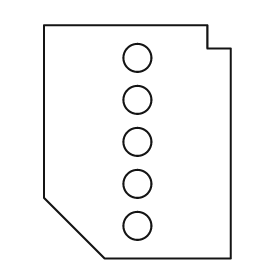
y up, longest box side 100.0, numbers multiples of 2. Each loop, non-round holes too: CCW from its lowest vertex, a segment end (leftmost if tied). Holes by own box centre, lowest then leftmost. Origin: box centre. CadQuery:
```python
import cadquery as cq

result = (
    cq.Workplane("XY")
    .moveTo(-14.0, -50.0)
    .lineTo(40.0, -50.0)
    .lineTo(40.0, 40.0)
    .lineTo(30.0, 40.0)
    .lineTo(30.0, 50.0)
    .lineTo(-40.0, 50.0)
    .lineTo(-40.0, -24.0)
    .close()
    .moveTo(0.0, -36.0)
    .circle(6.0)
    .moveTo(0.0, -18.0)
    .circle(6.0)
    .moveTo(0.0, 0.0)
    .circle(6.0)
    .moveTo(0.0, 18.0)
    .circle(6.0)
    .moveTo(0.0, 36.0)
    .circle(6.0)
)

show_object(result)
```